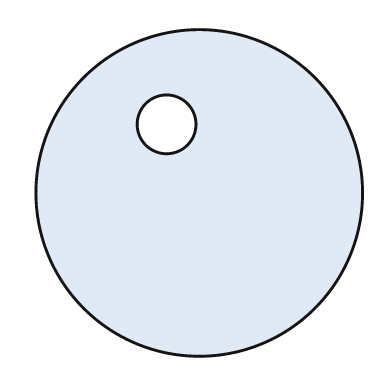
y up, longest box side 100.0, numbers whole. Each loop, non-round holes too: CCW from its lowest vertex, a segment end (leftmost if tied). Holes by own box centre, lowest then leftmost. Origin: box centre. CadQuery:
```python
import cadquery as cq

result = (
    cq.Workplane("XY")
    .moveTo(0.0, 0.0)
    .circle(50.0)
    .moveTo(-10.0, 21.0)
    .circle(9.0)
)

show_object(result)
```